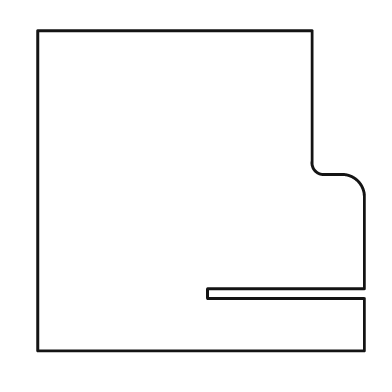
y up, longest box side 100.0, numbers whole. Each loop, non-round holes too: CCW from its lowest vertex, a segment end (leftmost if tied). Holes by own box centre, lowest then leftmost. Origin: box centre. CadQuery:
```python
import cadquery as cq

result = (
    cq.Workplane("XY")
    .moveTo(-50.0, -49.0)
    .lineTo(50.0, -49.0)
    .lineTo(50.0, -33.0)
    .lineTo(2.0, -33.0)
    .lineTo(2.0, -30.0)
    .lineTo(50.0, -30.0)
    .lineTo(50.0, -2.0)
    .threePointArc((48.0, 3.0), (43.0, 5.0))
    .lineTo(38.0, 5.0)
    .threePointArc((35.0, 6.0), (34.0, 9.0))
    .lineTo(34.0, 49.0)
    .lineTo(-50.0, 49.0)
    .close()
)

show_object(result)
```